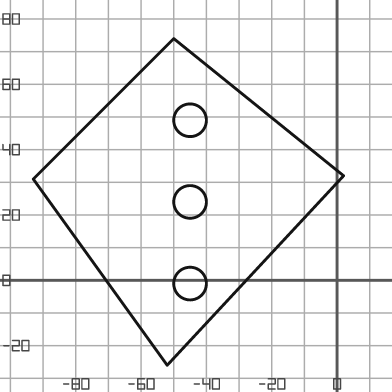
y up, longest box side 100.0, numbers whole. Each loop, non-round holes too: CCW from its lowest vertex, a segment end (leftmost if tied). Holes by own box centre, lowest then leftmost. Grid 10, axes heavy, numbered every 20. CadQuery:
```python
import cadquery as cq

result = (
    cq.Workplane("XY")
    .moveTo(-52.0, -26.0)
    .lineTo(2.0, 32.0)
    .lineTo(-50.0, 74.0)
    .lineTo(-93.0, 31.0)
    .close()
    .moveTo(-45.0, -1.0)
    .circle(5.0)
    .moveTo(-45.0, 24.0)
    .circle(5.0)
    .moveTo(-45.0, 49.0)
    .circle(5.0)
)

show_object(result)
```